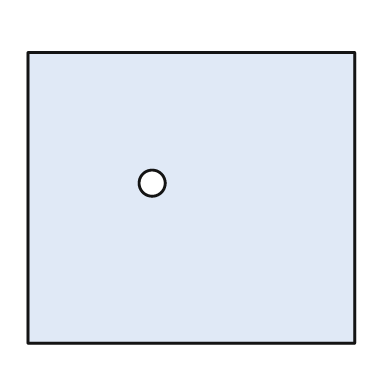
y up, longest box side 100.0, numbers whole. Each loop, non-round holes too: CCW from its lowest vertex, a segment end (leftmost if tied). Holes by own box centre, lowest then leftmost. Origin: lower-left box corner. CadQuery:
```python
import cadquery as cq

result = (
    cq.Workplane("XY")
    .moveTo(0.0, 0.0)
    .lineTo(100.0, 0.0)
    .lineTo(100.0, 89.0)
    .lineTo(0.0, 89.0)
    .close()
    .moveTo(38.0, 49.0)
    .circle(4.0)
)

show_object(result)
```